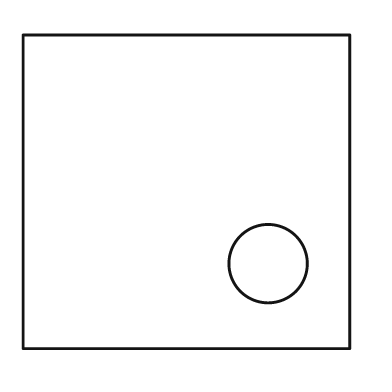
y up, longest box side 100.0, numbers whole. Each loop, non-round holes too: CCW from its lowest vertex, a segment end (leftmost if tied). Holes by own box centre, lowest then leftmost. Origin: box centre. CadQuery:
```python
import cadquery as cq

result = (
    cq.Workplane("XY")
    .moveTo(-50.0, -48.0)
    .lineTo(50.0, -48.0)
    .lineTo(50.0, 48.0)
    .lineTo(-50.0, 48.0)
    .close()
    .moveTo(25.0, -22.0)
    .circle(12.0)
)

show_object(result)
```